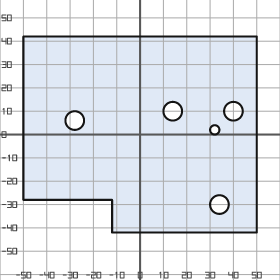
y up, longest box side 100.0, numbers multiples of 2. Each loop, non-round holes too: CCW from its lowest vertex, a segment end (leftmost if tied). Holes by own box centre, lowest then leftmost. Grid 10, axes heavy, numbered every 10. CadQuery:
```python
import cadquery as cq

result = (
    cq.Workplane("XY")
    .moveTo(-12.0, -42.0)
    .lineTo(50.0, -42.0)
    .lineTo(50.0, 42.0)
    .lineTo(-50.0, 42.0)
    .lineTo(-50.0, -28.0)
    .lineTo(-12.0, -28.0)
    .close()
    .moveTo(34.0, -30.0)
    .circle(4.0)
    .moveTo(32.0, 2.0)
    .circle(2.0)
    .moveTo(-28.0, 6.0)
    .circle(4.0)
    .moveTo(14.0, 10.0)
    .circle(4.0)
    .moveTo(40.0, 10.0)
    .circle(4.0)
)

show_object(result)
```